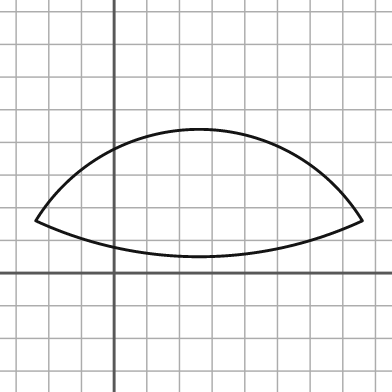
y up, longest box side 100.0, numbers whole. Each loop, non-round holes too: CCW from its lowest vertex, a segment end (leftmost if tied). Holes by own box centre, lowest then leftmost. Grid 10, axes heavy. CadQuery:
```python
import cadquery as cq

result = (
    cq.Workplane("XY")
    .moveTo(-24.0, 16.0)
    .threePointArc((26.0, 5.0), (76.0, 16.0))
    .threePointArc((26.0, 44.0), (-24.0, 16.0))
    .close()
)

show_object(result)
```